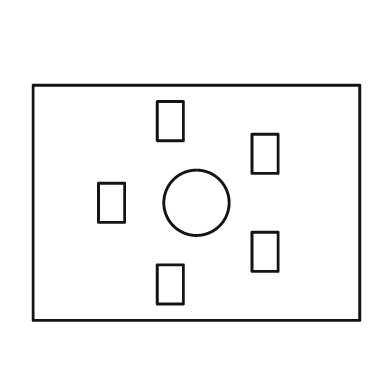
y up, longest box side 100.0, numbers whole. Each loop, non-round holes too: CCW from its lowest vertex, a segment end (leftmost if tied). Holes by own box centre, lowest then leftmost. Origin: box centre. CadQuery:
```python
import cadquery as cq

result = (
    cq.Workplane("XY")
    .moveTo(-50.0, -36.0)
    .lineTo(50.0, -36.0)
    .lineTo(50.0, 36.0)
    .lineTo(-50.0, 36.0)
    .close()
    .moveTo(-12.0, -31.0)
    .lineTo(-4.0, -31.0)
    .lineTo(-4.0, -19.0)
    .lineTo(-12.0, -19.0)
    .close()
    .moveTo(17.0, -21.0)
    .lineTo(25.0, -21.0)
    .lineTo(25.0, -9.0)
    .lineTo(17.0, -9.0)
    .close()
    .moveTo(-30.0, -6.0)
    .lineTo(-22.0, -6.0)
    .lineTo(-22.0, 6.0)
    .lineTo(-30.0, 6.0)
    .close()
    .moveTo(0.0, 0.0)
    .circle(10.0)
    .moveTo(17.0, 9.0)
    .lineTo(25.0, 9.0)
    .lineTo(25.0, 21.0)
    .lineTo(17.0, 21.0)
    .close()
    .moveTo(-12.0, 19.0)
    .lineTo(-4.0, 19.0)
    .lineTo(-4.0, 31.0)
    .lineTo(-12.0, 31.0)
    .close()
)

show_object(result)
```